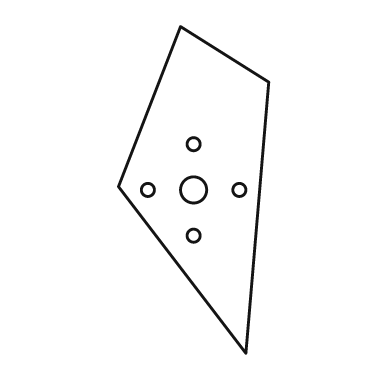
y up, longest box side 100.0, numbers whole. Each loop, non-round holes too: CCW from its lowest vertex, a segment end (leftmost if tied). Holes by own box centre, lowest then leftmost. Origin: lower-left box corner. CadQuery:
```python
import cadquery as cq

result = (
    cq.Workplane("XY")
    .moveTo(39.0, 0.0)
    .lineTo(46.0, 83.0)
    .lineTo(19.0, 100.0)
    .lineTo(0.0, 51.0)
    .close()
    .moveTo(23.0, 36.0)
    .circle(2.0)
    .moveTo(9.0, 50.0)
    .circle(2.0)
    .moveTo(23.0, 50.0)
    .circle(4.0)
    .moveTo(37.0, 50.0)
    .circle(2.0)
    .moveTo(23.0, 64.0)
    .circle(2.0)
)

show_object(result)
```